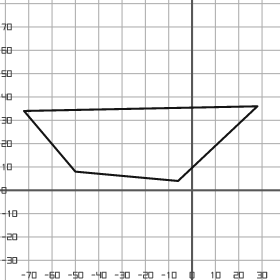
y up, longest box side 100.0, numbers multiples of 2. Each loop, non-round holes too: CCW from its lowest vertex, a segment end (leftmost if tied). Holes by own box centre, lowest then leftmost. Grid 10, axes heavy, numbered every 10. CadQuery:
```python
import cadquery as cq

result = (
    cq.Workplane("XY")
    .moveTo(-6.0, 4.0)
    .lineTo(28.0, 36.0)
    .lineTo(-72.0, 34.0)
    .lineTo(-50.0, 8.0)
    .close()
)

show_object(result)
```